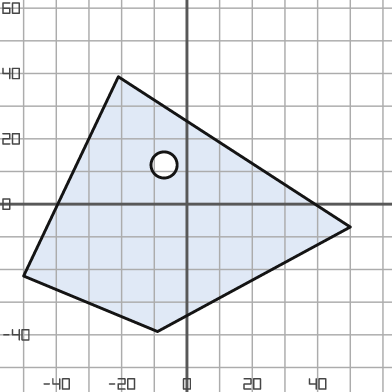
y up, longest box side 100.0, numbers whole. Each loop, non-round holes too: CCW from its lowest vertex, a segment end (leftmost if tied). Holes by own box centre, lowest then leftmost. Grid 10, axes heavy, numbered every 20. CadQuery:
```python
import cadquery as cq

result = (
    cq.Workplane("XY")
    .moveTo(-9.0, -39.0)
    .lineTo(50.0, -7.0)
    .lineTo(-21.0, 39.0)
    .lineTo(-50.0, -22.0)
    .close()
    .moveTo(-7.0, 12.0)
    .circle(4.0)
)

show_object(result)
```